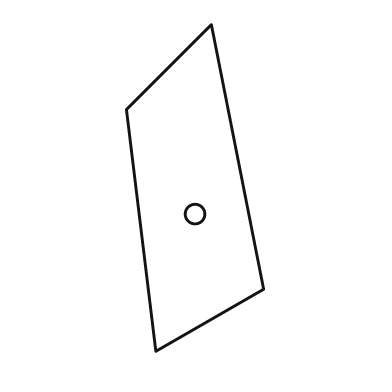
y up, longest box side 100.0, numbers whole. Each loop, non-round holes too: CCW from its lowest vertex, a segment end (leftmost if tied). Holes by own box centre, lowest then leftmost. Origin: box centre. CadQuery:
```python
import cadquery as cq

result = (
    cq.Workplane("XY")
    .moveTo(-12.0, -50.0)
    .lineTo(21.0, -31.0)
    .lineTo(5.0, 50.0)
    .lineTo(-21.0, 24.0)
    .close()
    .moveTo(0.0, -8.0)
    .circle(3.0)
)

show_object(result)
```